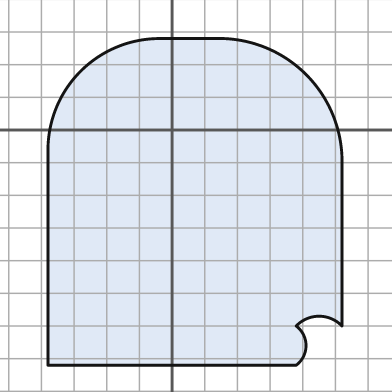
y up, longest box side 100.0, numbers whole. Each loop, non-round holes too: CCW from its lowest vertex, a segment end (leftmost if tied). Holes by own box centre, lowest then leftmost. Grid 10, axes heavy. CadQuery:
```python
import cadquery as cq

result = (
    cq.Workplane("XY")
    .moveTo(-38.0, -72.0)
    .lineTo(38.0, -72.0)
    .threePointArc((41.0, -66.0), (38.0, -60.0))
    .threePointArc((45.0, -57.0), (52.0, -60.0))
    .lineTo(52.0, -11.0)
    .threePointArc((41.0, 17.0), (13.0, 28.0))
    .lineTo(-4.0, 28.0)
    .threePointArc((-28.0, 18.0), (-38.0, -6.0))
    .close()
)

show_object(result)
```